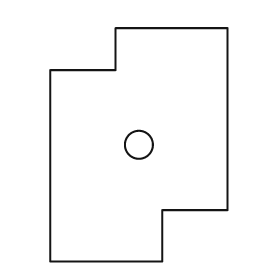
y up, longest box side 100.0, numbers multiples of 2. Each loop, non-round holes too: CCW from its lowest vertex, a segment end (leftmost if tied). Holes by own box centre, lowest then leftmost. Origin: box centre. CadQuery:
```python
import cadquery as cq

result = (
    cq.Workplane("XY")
    .moveTo(-38.0, -50.0)
    .lineTo(10.0, -50.0)
    .lineTo(10.0, -28.0)
    .lineTo(38.0, -28.0)
    .lineTo(38.0, 50.0)
    .lineTo(-10.0, 50.0)
    .lineTo(-10.0, 32.0)
    .lineTo(-38.0, 32.0)
    .close()
    .moveTo(0.0, 0.0)
    .circle(6.0)
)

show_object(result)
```